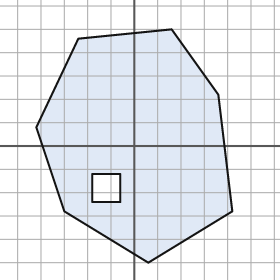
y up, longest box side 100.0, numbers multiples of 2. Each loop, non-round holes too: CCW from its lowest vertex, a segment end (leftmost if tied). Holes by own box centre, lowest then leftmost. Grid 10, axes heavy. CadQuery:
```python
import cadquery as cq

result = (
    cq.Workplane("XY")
    .moveTo(6.0, -50.0)
    .lineTo(42.0, -28.0)
    .lineTo(36.0, 22.0)
    .lineTo(16.0, 50.0)
    .lineTo(-24.0, 46.0)
    .lineTo(-42.0, 8.0)
    .lineTo(-30.0, -28.0)
    .close()
    .moveTo(-18.0, -24.0)
    .lineTo(-6.0, -24.0)
    .lineTo(-6.0, -12.0)
    .lineTo(-18.0, -12.0)
    .close()
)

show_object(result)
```